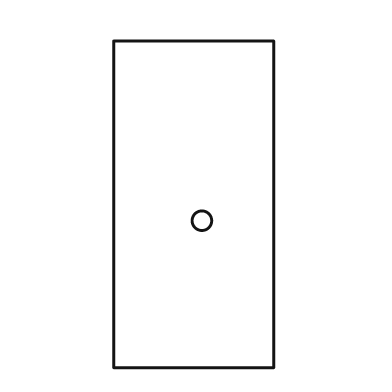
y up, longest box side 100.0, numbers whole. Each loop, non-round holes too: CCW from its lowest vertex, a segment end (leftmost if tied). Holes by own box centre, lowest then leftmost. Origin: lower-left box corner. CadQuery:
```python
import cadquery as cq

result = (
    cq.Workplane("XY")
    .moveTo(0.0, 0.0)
    .lineTo(49.0, 0.0)
    .lineTo(49.0, 100.0)
    .lineTo(0.0, 100.0)
    .close()
    .moveTo(27.0, 45.0)
    .circle(3.0)
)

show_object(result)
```